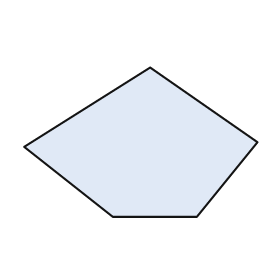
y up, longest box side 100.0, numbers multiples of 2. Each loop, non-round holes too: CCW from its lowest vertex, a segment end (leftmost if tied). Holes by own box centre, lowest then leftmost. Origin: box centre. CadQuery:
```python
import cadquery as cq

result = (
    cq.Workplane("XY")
    .moveTo(-12.0, -32.0)
    .lineTo(24.0, -32.0)
    .lineTo(50.0, 0.0)
    .lineTo(4.0, 32.0)
    .lineTo(-50.0, -2.0)
    .close()
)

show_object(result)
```